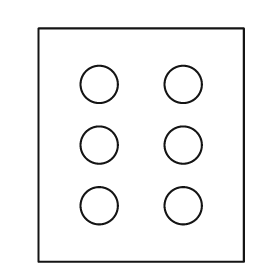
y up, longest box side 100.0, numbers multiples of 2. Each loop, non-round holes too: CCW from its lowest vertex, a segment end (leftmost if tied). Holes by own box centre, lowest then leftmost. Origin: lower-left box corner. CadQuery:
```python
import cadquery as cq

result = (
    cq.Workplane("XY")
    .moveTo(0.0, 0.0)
    .lineTo(88.0, 0.0)
    .lineTo(88.0, 100.0)
    .lineTo(0.0, 100.0)
    .close()
    .moveTo(26.0, 24.0)
    .circle(8.0)
    .moveTo(62.0, 24.0)
    .circle(8.0)
    .moveTo(26.0, 50.0)
    .circle(8.0)
    .moveTo(62.0, 50.0)
    .circle(8.0)
    .moveTo(26.0, 76.0)
    .circle(8.0)
    .moveTo(62.0, 76.0)
    .circle(8.0)
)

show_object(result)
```